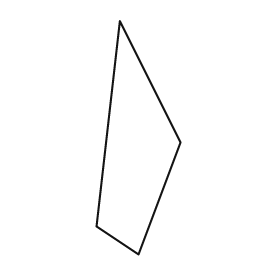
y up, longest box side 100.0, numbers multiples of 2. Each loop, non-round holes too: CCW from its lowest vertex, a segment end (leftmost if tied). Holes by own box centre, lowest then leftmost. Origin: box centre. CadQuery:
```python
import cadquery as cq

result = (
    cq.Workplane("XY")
    .moveTo(0.0, -50.0)
    .lineTo(18.0, -2.0)
    .lineTo(-8.0, 50.0)
    .lineTo(-18.0, -38.0)
    .close()
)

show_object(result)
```